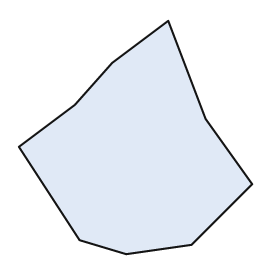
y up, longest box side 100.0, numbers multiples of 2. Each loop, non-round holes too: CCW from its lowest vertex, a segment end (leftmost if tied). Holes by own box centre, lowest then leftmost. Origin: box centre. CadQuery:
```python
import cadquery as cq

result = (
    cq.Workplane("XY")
    .moveTo(-4.0, -50.0)
    .lineTo(24.0, -46.0)
    .lineTo(50.0, -20.0)
    .lineTo(30.0, 8.0)
    .lineTo(14.0, 50.0)
    .lineTo(-10.0, 32.0)
    .lineTo(-26.0, 14.0)
    .lineTo(-50.0, -4.0)
    .lineTo(-24.0, -44.0)
    .close()
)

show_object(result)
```